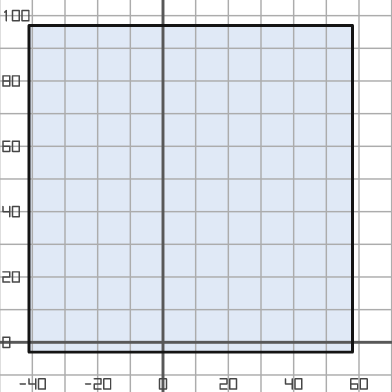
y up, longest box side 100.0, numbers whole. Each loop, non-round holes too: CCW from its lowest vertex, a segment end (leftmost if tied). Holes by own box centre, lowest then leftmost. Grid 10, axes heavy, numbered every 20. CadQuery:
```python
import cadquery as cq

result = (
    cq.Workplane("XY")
    .moveTo(-41.0, -3.0)
    .lineTo(58.0, -3.0)
    .lineTo(58.0, 97.0)
    .lineTo(-41.0, 97.0)
    .close()
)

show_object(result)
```